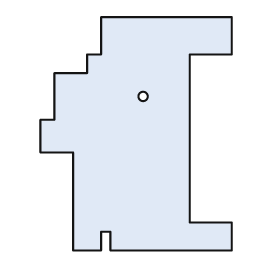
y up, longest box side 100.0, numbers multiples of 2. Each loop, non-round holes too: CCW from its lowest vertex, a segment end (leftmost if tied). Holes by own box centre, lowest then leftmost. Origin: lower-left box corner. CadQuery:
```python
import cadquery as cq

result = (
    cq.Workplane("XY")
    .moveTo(14.0, 0.0)
    .lineTo(26.0, 0.0)
    .lineTo(26.0, 8.0)
    .lineTo(30.0, 8.0)
    .lineTo(30.0, 0.0)
    .lineTo(82.0, 0.0)
    .lineTo(82.0, 12.0)
    .lineTo(64.0, 12.0)
    .lineTo(64.0, 84.0)
    .lineTo(82.0, 84.0)
    .lineTo(82.0, 100.0)
    .lineTo(26.0, 100.0)
    .lineTo(26.0, 84.0)
    .lineTo(20.0, 84.0)
    .lineTo(20.0, 76.0)
    .lineTo(6.0, 76.0)
    .lineTo(6.0, 56.0)
    .lineTo(0.0, 56.0)
    .lineTo(0.0, 42.0)
    .lineTo(14.0, 42.0)
    .close()
    .moveTo(44.0, 66.0)
    .circle(2.0)
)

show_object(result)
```